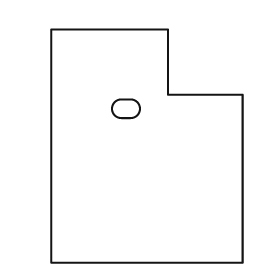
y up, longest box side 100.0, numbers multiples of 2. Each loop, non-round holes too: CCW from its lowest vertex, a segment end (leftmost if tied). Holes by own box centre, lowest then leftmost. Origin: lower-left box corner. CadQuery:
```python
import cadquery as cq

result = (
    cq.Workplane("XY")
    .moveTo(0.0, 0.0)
    .lineTo(82.0, 0.0)
    .lineTo(82.0, 72.0)
    .lineTo(50.0, 72.0)
    .lineTo(50.0, 100.0)
    .lineTo(0.0, 100.0)
    .close()
    .moveTo(30.0, 62.0)
    .lineTo(34.0, 62.0)
    .threePointArc((38.0, 66.0), (34.0, 70.0))
    .lineTo(30.0, 70.0)
    .threePointArc((26.0, 66.0), (30.0, 62.0))
    .close()
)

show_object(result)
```